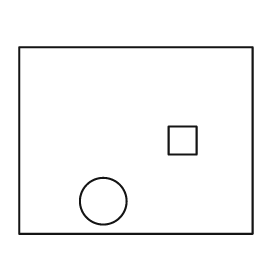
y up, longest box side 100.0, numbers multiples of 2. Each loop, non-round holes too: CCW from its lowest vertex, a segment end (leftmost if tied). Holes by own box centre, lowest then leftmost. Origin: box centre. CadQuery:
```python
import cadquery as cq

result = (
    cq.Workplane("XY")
    .moveTo(-50.0, -40.0)
    .lineTo(50.0, -40.0)
    .lineTo(50.0, 40.0)
    .lineTo(-50.0, 40.0)
    .close()
    .moveTo(-14.0, -26.0)
    .circle(10.0)
    .moveTo(14.0, -6.0)
    .lineTo(26.0, -6.0)
    .lineTo(26.0, 6.0)
    .lineTo(14.0, 6.0)
    .close()
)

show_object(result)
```